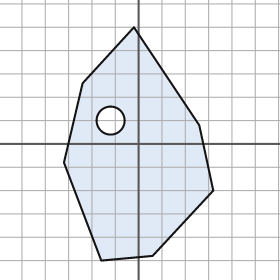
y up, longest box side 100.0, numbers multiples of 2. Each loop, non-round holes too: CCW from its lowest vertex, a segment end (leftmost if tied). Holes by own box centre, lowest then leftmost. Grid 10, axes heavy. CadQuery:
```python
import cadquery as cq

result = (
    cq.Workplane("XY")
    .moveTo(-16.0, -50.0)
    .lineTo(6.0, -48.0)
    .lineTo(32.0, -20.0)
    .lineTo(26.0, 8.0)
    .lineTo(-2.0, 50.0)
    .lineTo(-24.0, 26.0)
    .lineTo(-32.0, -8.0)
    .close()
    .moveTo(-12.0, 10.0)
    .circle(6.0)
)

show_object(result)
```